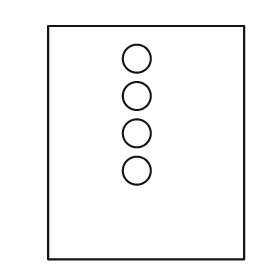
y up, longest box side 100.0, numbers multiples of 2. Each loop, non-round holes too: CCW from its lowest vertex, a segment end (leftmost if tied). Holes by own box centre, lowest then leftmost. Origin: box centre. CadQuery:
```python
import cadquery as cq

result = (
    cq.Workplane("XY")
    .moveTo(-42.0, -50.0)
    .lineTo(42.0, -50.0)
    .lineTo(42.0, 50.0)
    .lineTo(-42.0, 50.0)
    .close()
    .moveTo(-4.0, -12.0)
    .circle(6.0)
    .moveTo(-4.0, 4.0)
    .circle(6.0)
    .moveTo(-4.0, 20.0)
    .circle(6.0)
    .moveTo(-4.0, 36.0)
    .circle(6.0)
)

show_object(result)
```